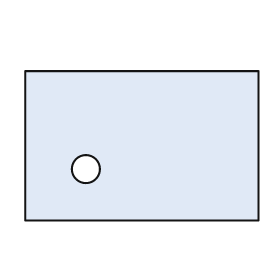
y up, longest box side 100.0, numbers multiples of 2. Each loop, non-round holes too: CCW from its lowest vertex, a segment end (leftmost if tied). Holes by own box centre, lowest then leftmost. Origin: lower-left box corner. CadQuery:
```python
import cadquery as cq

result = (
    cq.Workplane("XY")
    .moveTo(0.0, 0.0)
    .lineTo(100.0, 0.0)
    .lineTo(100.0, 64.0)
    .lineTo(0.0, 64.0)
    .close()
    .moveTo(26.0, 22.0)
    .circle(6.0)
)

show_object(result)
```